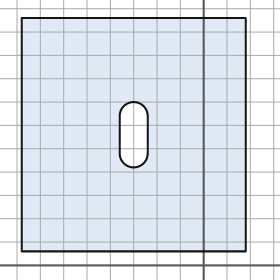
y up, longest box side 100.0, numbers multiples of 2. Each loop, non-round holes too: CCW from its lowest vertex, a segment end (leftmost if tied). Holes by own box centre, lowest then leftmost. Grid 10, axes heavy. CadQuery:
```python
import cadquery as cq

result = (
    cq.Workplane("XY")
    .moveTo(-78.0, 6.0)
    .lineTo(18.0, 6.0)
    .lineTo(18.0, 106.0)
    .lineTo(-78.0, 106.0)
    .close()
    .moveTo(-36.0, 48.0)
    .threePointArc((-30.0, 42.0), (-24.0, 48.0))
    .lineTo(-24.0, 64.0)
    .threePointArc((-30.0, 70.0), (-36.0, 64.0))
    .close()
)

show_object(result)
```